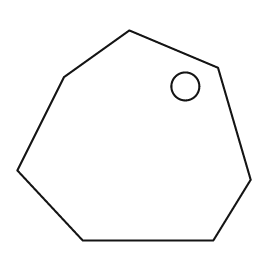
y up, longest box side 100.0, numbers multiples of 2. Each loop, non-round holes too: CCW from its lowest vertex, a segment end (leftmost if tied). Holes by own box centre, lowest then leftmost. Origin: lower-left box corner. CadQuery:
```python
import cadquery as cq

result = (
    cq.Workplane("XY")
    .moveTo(28.0, 0.0)
    .lineTo(84.0, 0.0)
    .lineTo(100.0, 26.0)
    .lineTo(86.0, 74.0)
    .lineTo(48.0, 90.0)
    .lineTo(20.0, 70.0)
    .lineTo(0.0, 30.0)
    .close()
    .moveTo(72.0, 66.0)
    .circle(6.0)
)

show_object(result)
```